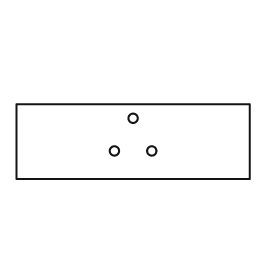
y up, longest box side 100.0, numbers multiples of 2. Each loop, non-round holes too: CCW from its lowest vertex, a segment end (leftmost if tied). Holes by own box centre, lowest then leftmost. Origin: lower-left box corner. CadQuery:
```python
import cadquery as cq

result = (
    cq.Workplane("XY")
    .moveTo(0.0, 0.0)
    .lineTo(100.0, 0.0)
    .lineTo(100.0, 32.0)
    .lineTo(0.0, 32.0)
    .close()
    .moveTo(42.0, 12.0)
    .circle(2.0)
    .moveTo(58.0, 12.0)
    .circle(2.0)
    .moveTo(50.0, 26.0)
    .circle(2.0)
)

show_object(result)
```